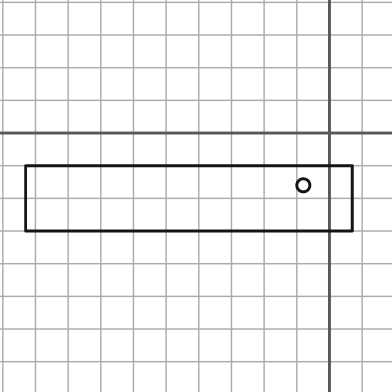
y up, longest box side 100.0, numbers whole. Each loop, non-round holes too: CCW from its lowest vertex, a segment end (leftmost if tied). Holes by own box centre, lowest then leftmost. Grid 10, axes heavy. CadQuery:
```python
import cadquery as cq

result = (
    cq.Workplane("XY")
    .moveTo(-93.0, -30.0)
    .lineTo(7.0, -30.0)
    .lineTo(7.0, -10.0)
    .lineTo(-93.0, -10.0)
    .close()
    .moveTo(-8.0, -16.0)
    .circle(2.0)
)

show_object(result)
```